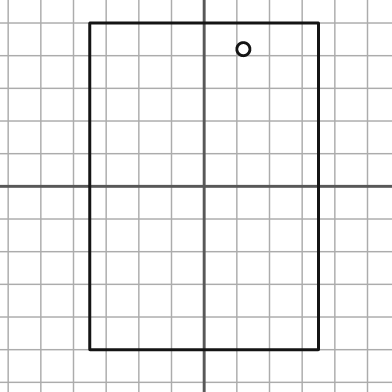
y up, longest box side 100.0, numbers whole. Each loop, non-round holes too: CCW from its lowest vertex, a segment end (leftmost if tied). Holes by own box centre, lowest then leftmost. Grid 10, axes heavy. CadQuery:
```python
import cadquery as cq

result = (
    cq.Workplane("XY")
    .moveTo(-35.0, -50.0)
    .lineTo(35.0, -50.0)
    .lineTo(35.0, 50.0)
    .lineTo(-35.0, 50.0)
    .close()
    .moveTo(12.0, 42.0)
    .circle(2.0)
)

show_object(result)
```